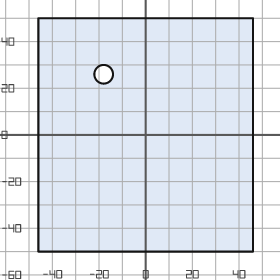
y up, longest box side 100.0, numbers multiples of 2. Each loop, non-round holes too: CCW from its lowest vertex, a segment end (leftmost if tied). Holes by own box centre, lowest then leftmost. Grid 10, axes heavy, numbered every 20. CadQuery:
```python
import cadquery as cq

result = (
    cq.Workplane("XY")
    .moveTo(-46.0, -50.0)
    .lineTo(46.0, -50.0)
    .lineTo(46.0, 50.0)
    .lineTo(-46.0, 50.0)
    .close()
    .moveTo(-18.0, 26.0)
    .circle(4.0)
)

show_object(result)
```